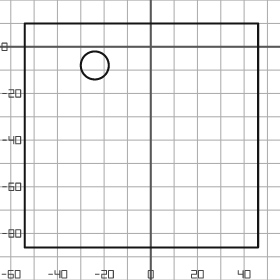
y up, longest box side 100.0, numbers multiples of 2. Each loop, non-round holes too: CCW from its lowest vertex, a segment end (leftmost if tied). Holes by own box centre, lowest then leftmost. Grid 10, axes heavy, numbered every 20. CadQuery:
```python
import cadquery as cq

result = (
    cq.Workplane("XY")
    .moveTo(-54.0, -86.0)
    .lineTo(46.0, -86.0)
    .lineTo(46.0, 10.0)
    .lineTo(-54.0, 10.0)
    .close()
    .moveTo(-24.0, -8.0)
    .circle(6.0)
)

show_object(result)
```